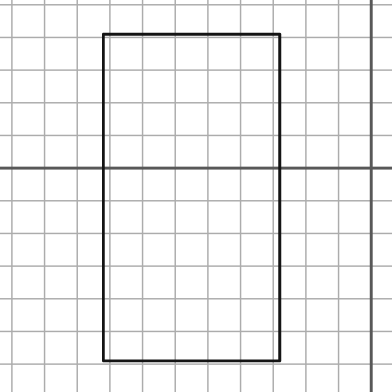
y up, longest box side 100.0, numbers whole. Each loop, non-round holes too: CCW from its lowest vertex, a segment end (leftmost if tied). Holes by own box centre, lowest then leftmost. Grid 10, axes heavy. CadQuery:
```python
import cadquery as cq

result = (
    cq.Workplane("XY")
    .moveTo(-82.0, -59.0)
    .lineTo(-28.0, -59.0)
    .lineTo(-28.0, 41.0)
    .lineTo(-82.0, 41.0)
    .close()
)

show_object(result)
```